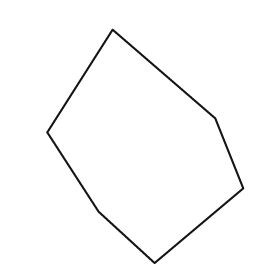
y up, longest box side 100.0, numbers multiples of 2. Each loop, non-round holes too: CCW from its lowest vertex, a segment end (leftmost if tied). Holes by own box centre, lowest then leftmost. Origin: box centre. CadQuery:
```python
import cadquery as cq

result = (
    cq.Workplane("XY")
    .moveTo(4.0, -50.0)
    .lineTo(42.0, -18.0)
    .lineTo(30.0, 12.0)
    .lineTo(-14.0, 50.0)
    .lineTo(-42.0, 6.0)
    .lineTo(-20.0, -28.0)
    .close()
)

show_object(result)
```